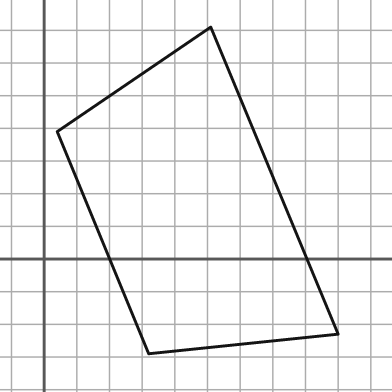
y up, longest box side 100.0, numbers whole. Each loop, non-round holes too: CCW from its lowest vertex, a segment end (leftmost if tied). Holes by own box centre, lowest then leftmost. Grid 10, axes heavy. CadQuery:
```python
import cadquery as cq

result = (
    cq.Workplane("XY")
    .moveTo(32.0, -29.0)
    .lineTo(90.0, -23.0)
    .lineTo(51.0, 71.0)
    .lineTo(4.0, 39.0)
    .close()
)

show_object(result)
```